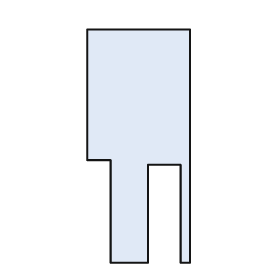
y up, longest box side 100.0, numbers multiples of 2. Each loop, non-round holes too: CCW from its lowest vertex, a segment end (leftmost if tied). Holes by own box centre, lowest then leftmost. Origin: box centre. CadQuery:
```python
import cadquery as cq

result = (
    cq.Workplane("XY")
    .moveTo(-12.0, -50.0)
    .lineTo(4.0, -50.0)
    .lineTo(4.0, -8.0)
    .lineTo(18.0, -8.0)
    .lineTo(18.0, -50.0)
    .lineTo(22.0, -50.0)
    .lineTo(22.0, 50.0)
    .lineTo(-22.0, 50.0)
    .lineTo(-22.0, -6.0)
    .lineTo(-12.0, -6.0)
    .close()
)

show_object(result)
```